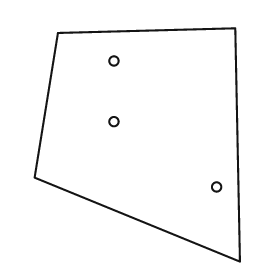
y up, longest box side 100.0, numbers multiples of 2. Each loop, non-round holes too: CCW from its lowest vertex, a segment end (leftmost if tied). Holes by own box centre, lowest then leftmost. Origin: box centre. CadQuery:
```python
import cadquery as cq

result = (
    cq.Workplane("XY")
    .moveTo(44.0, -50.0)
    .lineTo(42.0, 50.0)
    .lineTo(-34.0, 48.0)
    .lineTo(-44.0, -14.0)
    .close()
    .moveTo(34.0, -18.0)
    .circle(2.0)
    .moveTo(-10.0, 10.0)
    .circle(2.0)
    .moveTo(-10.0, 36.0)
    .circle(2.0)
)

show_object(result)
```